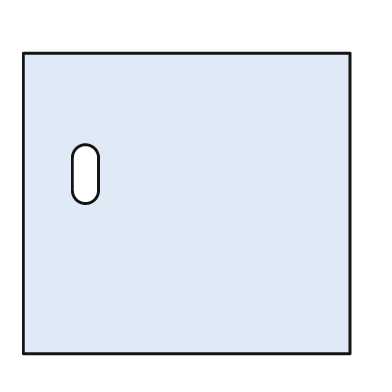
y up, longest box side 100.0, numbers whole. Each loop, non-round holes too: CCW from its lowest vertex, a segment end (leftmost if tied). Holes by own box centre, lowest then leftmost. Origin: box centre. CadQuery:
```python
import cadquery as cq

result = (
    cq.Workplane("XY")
    .moveTo(-50.0, -46.0)
    .lineTo(50.0, -46.0)
    .lineTo(50.0, 46.0)
    .lineTo(-50.0, 46.0)
    .close()
    .moveTo(-35.0, 4.0)
    .threePointArc((-31.0, 0.0), (-27.0, 4.0))
    .lineTo(-27.0, 14.0)
    .threePointArc((-31.0, 18.0), (-35.0, 14.0))
    .close()
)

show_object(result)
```